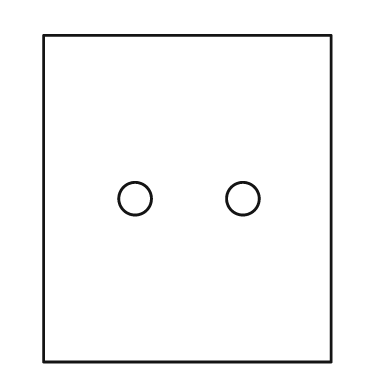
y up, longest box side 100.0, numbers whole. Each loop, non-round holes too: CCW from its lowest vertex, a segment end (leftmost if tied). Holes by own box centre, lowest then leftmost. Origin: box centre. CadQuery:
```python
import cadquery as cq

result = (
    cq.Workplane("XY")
    .moveTo(-44.0, -50.0)
    .lineTo(44.0, -50.0)
    .lineTo(44.0, 50.0)
    .lineTo(-44.0, 50.0)
    .close()
    .moveTo(-16.0, 0.0)
    .circle(5.0)
    .moveTo(17.0, 0.0)
    .circle(5.0)
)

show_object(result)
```